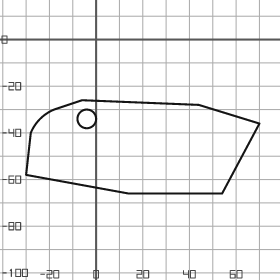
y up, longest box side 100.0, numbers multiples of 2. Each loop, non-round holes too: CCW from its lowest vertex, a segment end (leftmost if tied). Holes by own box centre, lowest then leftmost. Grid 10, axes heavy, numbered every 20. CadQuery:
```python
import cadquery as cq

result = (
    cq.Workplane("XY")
    .moveTo(14.0, -66.0)
    .lineTo(54.0, -66.0)
    .lineTo(70.0, -36.0)
    .lineTo(44.0, -28.0)
    .lineTo(-6.0, -26.0)
    .lineTo(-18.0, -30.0)
    .threePointArc((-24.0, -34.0), (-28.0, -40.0))
    .lineTo(-30.0, -58.0)
    .close()
    .moveTo(-4.0, -34.0)
    .circle(4.0)
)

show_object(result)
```